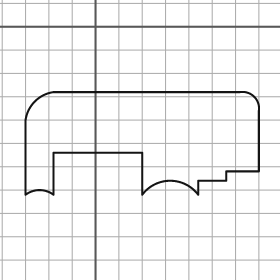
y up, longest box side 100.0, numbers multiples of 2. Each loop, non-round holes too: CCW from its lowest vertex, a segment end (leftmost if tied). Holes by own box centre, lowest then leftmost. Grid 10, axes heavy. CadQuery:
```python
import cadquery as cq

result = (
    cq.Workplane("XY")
    .moveTo(-30.0, -72.0)
    .threePointArc((-24.0, -70.0), (-18.0, -72.0))
    .lineTo(-18.0, -54.0)
    .lineTo(20.0, -54.0)
    .lineTo(20.0, -72.0)
    .threePointArc((32.0, -66.0), (44.0, -72.0))
    .lineTo(44.0, -66.0)
    .lineTo(56.0, -66.0)
    .lineTo(56.0, -62.0)
    .lineTo(70.0, -62.0)
    .lineTo(70.0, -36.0)
    .threePointArc((68.0, -30.0), (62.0, -28.0))
    .lineTo(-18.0, -28.0)
    .threePointArc((-26.0, -32.0), (-30.0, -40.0))
    .close()
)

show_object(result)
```